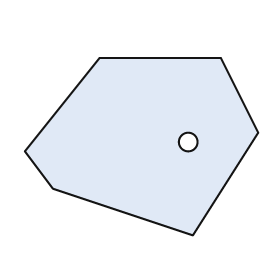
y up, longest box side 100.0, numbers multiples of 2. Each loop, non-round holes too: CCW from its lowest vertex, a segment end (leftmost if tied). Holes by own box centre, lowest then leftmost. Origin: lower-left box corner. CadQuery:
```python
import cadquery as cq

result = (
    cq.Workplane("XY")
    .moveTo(72.0, 0.0)
    .lineTo(100.0, 44.0)
    .lineTo(84.0, 76.0)
    .lineTo(32.0, 76.0)
    .lineTo(0.0, 36.0)
    .lineTo(12.0, 20.0)
    .close()
    .moveTo(70.0, 40.0)
    .circle(4.0)
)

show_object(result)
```